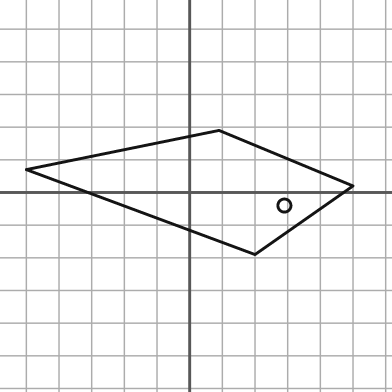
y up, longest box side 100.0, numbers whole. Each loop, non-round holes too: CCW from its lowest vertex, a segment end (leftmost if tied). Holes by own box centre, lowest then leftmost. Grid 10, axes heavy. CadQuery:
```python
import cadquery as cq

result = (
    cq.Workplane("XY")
    .moveTo(20.0, -19.0)
    .lineTo(50.0, 2.0)
    .lineTo(9.0, 19.0)
    .lineTo(-50.0, 7.0)
    .close()
    .moveTo(29.0, -4.0)
    .circle(2.0)
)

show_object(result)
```